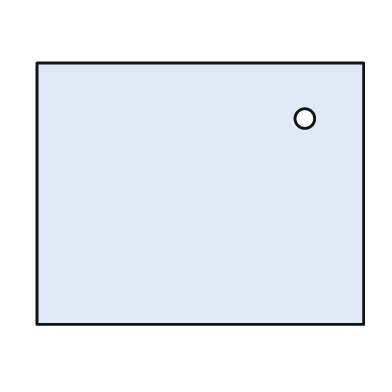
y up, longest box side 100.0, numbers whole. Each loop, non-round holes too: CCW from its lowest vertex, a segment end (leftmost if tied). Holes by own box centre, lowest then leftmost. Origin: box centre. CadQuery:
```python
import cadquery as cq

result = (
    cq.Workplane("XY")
    .moveTo(-50.0, -40.0)
    .lineTo(50.0, -40.0)
    .lineTo(50.0, 40.0)
    .lineTo(-50.0, 40.0)
    .close()
    .moveTo(32.0, 23.0)
    .circle(3.0)
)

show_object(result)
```